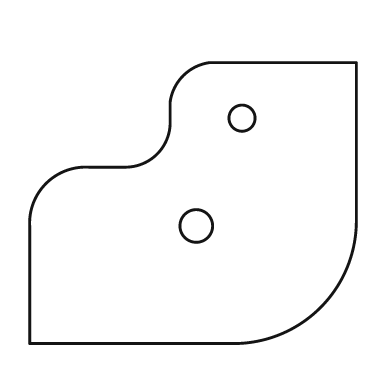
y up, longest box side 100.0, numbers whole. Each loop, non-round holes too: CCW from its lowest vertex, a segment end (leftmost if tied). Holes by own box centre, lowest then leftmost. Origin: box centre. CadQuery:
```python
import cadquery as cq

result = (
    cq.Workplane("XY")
    .moveTo(-50.0, -43.0)
    .lineTo(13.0, -43.0)
    .threePointArc((39.0, -32.0), (50.0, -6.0))
    .lineTo(50.0, 43.0)
    .lineTo(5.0, 43.0)
    .threePointArc((-3.0, 39.0), (-7.0, 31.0))
    .lineTo(-7.0, 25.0)
    .threePointArc((-11.0, 15.0), (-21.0, 11.0))
    .lineTo(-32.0, 11.0)
    .threePointArc((-45.0, 6.0), (-50.0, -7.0))
    .close()
    .moveTo(1.0, -7.0)
    .circle(5.0)
    .moveTo(15.0, 26.0)
    .circle(4.0)
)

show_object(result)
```